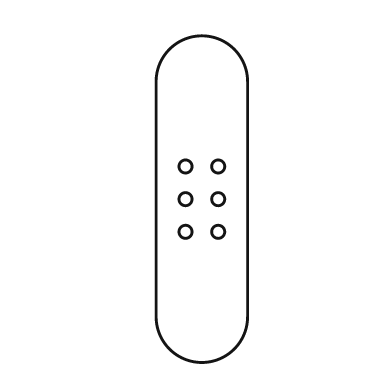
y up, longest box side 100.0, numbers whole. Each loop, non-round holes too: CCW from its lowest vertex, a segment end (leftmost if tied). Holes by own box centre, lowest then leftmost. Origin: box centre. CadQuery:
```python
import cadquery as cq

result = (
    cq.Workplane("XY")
    .moveTo(-14.0, -36.0)
    .threePointArc((0.0, -50.0), (14.0, -36.0))
    .lineTo(14.0, 36.0)
    .threePointArc((0.0, 50.0), (-14.0, 36.0))
    .close()
    .moveTo(-5.0, -10.0)
    .circle(2.0)
    .moveTo(5.0, -10.0)
    .circle(2.0)
    .moveTo(-5.0, 0.0)
    .circle(2.0)
    .moveTo(5.0, 0.0)
    .circle(2.0)
    .moveTo(-5.0, 10.0)
    .circle(2.0)
    .moveTo(5.0, 10.0)
    .circle(2.0)
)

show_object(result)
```